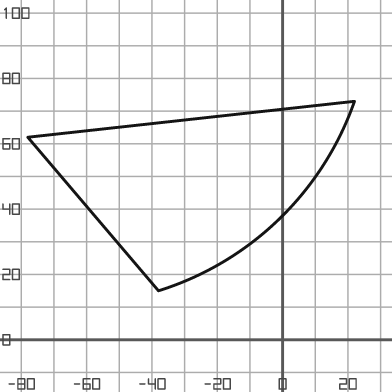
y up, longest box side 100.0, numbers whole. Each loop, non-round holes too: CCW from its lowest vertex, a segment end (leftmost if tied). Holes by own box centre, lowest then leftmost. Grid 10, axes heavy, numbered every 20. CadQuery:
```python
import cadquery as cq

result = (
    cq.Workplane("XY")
    .moveTo(-38.0, 15.0)
    .threePointArc((-1.0, 37.0), (22.0, 73.0))
    .lineTo(-78.0, 62.0)
    .close()
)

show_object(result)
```